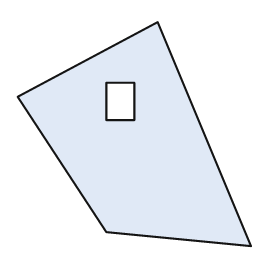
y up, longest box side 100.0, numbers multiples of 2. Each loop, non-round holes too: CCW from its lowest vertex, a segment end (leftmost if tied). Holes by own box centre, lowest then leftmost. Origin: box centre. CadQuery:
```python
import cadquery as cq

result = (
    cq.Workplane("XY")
    .moveTo(50.0, -48.0)
    .lineTo(10.0, 48.0)
    .lineTo(-50.0, 16.0)
    .lineTo(-12.0, -42.0)
    .close()
    .moveTo(-12.0, 6.0)
    .lineTo(0.0, 6.0)
    .lineTo(0.0, 22.0)
    .lineTo(-12.0, 22.0)
    .close()
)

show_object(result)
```